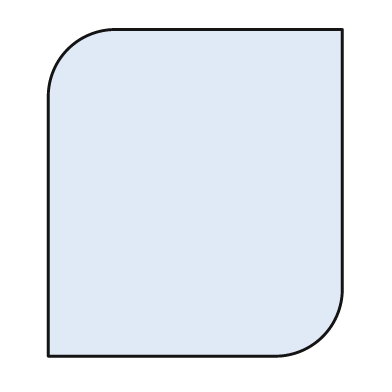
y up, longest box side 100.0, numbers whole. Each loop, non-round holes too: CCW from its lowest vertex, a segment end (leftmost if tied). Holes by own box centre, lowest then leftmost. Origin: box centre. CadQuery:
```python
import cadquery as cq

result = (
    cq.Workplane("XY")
    .moveTo(-45.0, -50.0)
    .lineTo(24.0, -50.0)
    .threePointArc((39.0, -44.0), (45.0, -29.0))
    .lineTo(45.0, 50.0)
    .lineTo(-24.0, 50.0)
    .threePointArc((-39.0, 44.0), (-45.0, 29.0))
    .close()
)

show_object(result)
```